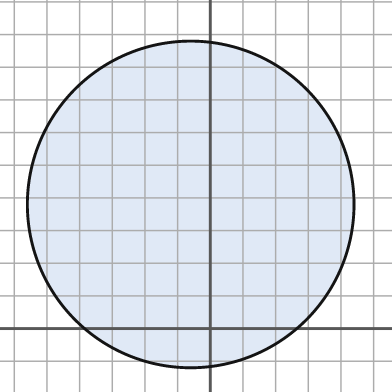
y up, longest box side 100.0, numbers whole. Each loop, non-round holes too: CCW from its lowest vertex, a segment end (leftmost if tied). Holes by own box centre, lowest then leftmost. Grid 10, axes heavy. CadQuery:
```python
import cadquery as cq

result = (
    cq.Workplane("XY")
    .moveTo(-6.0, 38.0)
    .circle(50.0)
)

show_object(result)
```